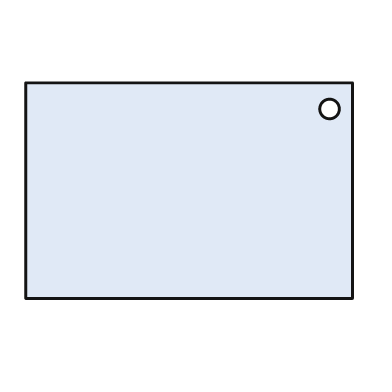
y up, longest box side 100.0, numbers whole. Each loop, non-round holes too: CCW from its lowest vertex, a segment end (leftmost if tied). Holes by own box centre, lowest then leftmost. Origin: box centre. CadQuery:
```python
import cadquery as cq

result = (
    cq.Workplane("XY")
    .moveTo(-50.0, -33.0)
    .lineTo(50.0, -33.0)
    .lineTo(50.0, 33.0)
    .lineTo(-50.0, 33.0)
    .close()
    .moveTo(43.0, 25.0)
    .circle(3.0)
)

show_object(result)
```